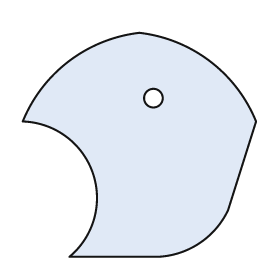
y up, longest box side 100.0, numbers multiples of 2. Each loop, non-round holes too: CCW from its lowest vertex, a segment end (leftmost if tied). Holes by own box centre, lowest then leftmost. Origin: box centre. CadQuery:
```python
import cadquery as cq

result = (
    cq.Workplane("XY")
    .moveTo(-30.0, -48.0)
    .lineTo(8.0, -48.0)
    .threePointArc((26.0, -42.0), (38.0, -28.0))
    .lineTo(50.0, 10.0)
    .threePointArc((30.0, 36.0), (0.0, 48.0))
    .threePointArc((-30.0, 36.0), (-50.0, 10.0))
    .threePointArc((-20.0, -12.0), (-30.0, -48.0))
    .close()
    .moveTo(6.0, 20.0)
    .circle(4.0)
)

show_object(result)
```